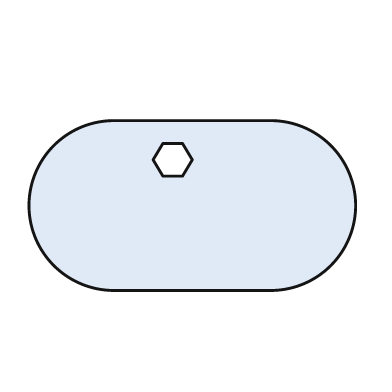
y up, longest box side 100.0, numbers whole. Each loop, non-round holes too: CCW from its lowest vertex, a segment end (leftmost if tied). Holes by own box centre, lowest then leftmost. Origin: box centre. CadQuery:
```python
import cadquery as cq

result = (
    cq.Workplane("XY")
    .moveTo(-24.0, -26.0)
    .lineTo(24.0, -26.0)
    .threePointArc((50.0, 0.0), (24.0, 26.0))
    .lineTo(-24.0, 26.0)
    .threePointArc((-50.0, 0.0), (-24.0, -26.0))
    .close()
    .moveTo(-9.0, 9.0)
    .lineTo(-3.0, 9.0)
    .lineTo(0.0, 14.0)
    .lineTo(-3.0, 19.0)
    .lineTo(-9.0, 19.0)
    .lineTo(-12.0, 14.0)
    .close()
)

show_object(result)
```